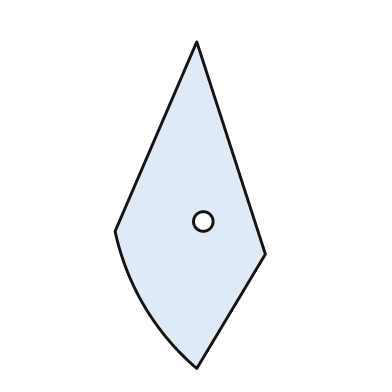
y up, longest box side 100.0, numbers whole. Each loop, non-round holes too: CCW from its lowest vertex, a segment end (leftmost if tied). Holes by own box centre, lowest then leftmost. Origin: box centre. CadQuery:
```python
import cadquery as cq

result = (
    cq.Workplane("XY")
    .moveTo(2.0, -50.0)
    .lineTo(23.0, -15.0)
    .lineTo(2.0, 50.0)
    .lineTo(-23.0, -8.0)
    .threePointArc((-14.0, -31.0), (2.0, -50.0))
    .close()
    .moveTo(4.0, -5.0)
    .circle(3.0)
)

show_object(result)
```